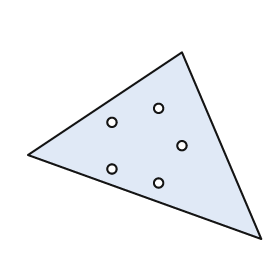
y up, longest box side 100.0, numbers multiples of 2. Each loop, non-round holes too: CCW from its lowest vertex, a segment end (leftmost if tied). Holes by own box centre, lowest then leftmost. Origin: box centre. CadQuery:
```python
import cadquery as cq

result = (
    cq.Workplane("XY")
    .moveTo(50.0, -40.0)
    .lineTo(16.0, 40.0)
    .lineTo(-50.0, -4.0)
    .close()
    .moveTo(6.0, -16.0)
    .circle(2.0)
    .moveTo(-14.0, -10.0)
    .circle(2.0)
    .moveTo(16.0, 0.0)
    .circle(2.0)
    .moveTo(-14.0, 10.0)
    .circle(2.0)
    .moveTo(6.0, 16.0)
    .circle(2.0)
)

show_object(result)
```